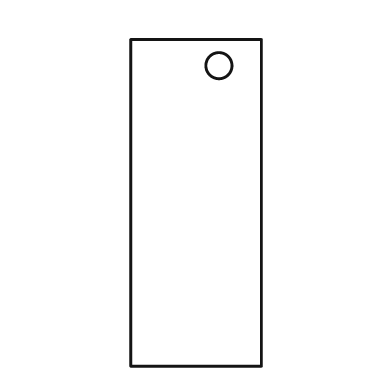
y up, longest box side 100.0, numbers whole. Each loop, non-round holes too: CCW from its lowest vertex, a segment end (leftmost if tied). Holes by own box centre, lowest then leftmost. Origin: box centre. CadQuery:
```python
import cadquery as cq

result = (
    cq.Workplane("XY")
    .moveTo(-20.0, -50.0)
    .lineTo(20.0, -50.0)
    .lineTo(20.0, 50.0)
    .lineTo(-20.0, 50.0)
    .close()
    .moveTo(7.0, 42.0)
    .circle(4.0)
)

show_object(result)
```